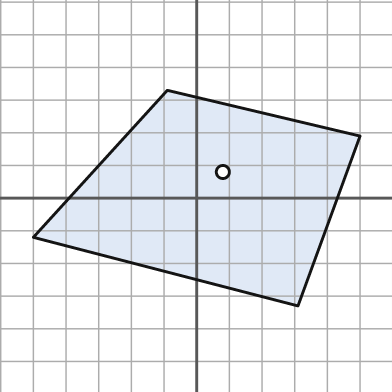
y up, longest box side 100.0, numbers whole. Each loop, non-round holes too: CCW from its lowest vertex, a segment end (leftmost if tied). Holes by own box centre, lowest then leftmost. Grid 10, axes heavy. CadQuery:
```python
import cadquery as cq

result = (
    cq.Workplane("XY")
    .moveTo(31.0, -33.0)
    .lineTo(50.0, 19.0)
    .lineTo(-9.0, 33.0)
    .lineTo(-50.0, -12.0)
    .close()
    .moveTo(8.0, 8.0)
    .circle(2.0)
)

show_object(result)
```